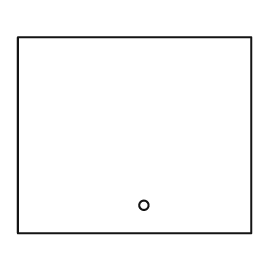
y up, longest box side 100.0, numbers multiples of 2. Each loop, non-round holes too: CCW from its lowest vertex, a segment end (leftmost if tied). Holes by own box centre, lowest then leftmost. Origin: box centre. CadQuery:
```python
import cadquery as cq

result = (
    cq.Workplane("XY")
    .moveTo(-50.0, -42.0)
    .lineTo(50.0, -42.0)
    .lineTo(50.0, 42.0)
    .lineTo(-50.0, 42.0)
    .close()
    .moveTo(4.0, -30.0)
    .circle(2.0)
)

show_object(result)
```